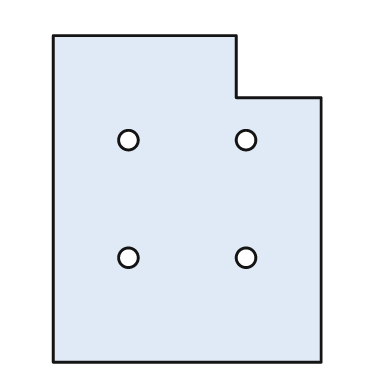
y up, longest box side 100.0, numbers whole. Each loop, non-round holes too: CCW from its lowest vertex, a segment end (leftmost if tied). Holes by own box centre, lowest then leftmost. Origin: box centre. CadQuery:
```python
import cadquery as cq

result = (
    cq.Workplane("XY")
    .moveTo(-41.0, -50.0)
    .lineTo(41.0, -50.0)
    .lineTo(41.0, 31.0)
    .lineTo(15.0, 31.0)
    .lineTo(15.0, 50.0)
    .lineTo(-41.0, 50.0)
    .close()
    .moveTo(-18.0, -18.0)
    .circle(3.0)
    .moveTo(18.0, -18.0)
    .circle(3.0)
    .moveTo(-18.0, 18.0)
    .circle(3.0)
    .moveTo(18.0, 18.0)
    .circle(3.0)
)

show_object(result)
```